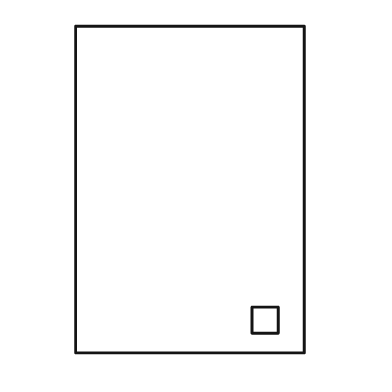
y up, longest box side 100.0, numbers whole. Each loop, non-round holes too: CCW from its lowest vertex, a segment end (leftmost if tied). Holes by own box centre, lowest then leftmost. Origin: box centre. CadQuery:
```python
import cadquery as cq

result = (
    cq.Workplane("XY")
    .moveTo(-35.0, -50.0)
    .lineTo(35.0, -50.0)
    .lineTo(35.0, 50.0)
    .lineTo(-35.0, 50.0)
    .close()
    .moveTo(19.0, -44.0)
    .lineTo(27.0, -44.0)
    .lineTo(27.0, -36.0)
    .lineTo(19.0, -36.0)
    .close()
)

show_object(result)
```